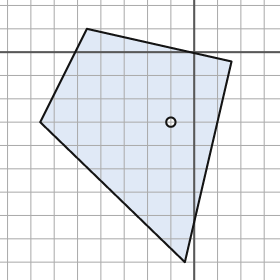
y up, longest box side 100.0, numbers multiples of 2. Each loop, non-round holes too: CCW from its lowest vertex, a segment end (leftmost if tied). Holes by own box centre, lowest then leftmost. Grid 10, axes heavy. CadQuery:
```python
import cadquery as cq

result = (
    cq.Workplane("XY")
    .moveTo(-4.0, -90.0)
    .lineTo(16.0, -4.0)
    .lineTo(-46.0, 10.0)
    .lineTo(-66.0, -30.0)
    .close()
    .moveTo(-10.0, -30.0)
    .circle(2.0)
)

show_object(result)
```